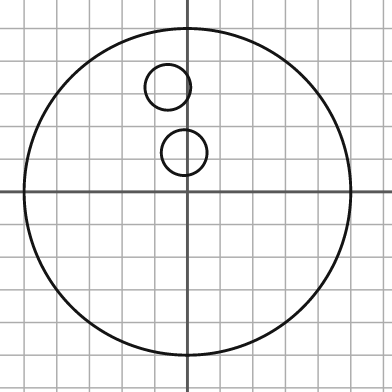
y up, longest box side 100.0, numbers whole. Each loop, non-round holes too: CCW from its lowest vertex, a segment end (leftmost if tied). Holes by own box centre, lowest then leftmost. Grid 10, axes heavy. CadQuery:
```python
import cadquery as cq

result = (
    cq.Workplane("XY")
    .moveTo(0.0, 0.0)
    .circle(50.0)
    .moveTo(-1.0, 12.0)
    .circle(7.0)
    .moveTo(-6.0, 32.0)
    .circle(7.0)
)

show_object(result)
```